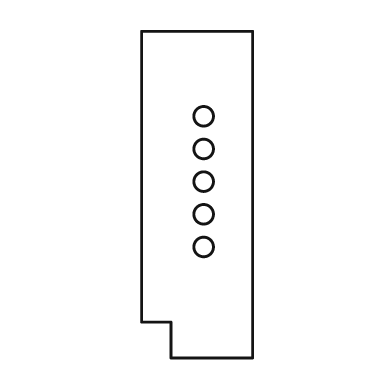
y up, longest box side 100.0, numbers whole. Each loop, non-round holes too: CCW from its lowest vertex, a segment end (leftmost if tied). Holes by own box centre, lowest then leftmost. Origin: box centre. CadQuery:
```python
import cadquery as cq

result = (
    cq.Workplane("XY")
    .moveTo(-8.0, -50.0)
    .lineTo(17.0, -50.0)
    .lineTo(17.0, 50.0)
    .lineTo(-17.0, 50.0)
    .lineTo(-17.0, -39.0)
    .lineTo(-8.0, -39.0)
    .close()
    .moveTo(2.0, -16.0)
    .circle(3.0)
    .moveTo(2.0, -6.0)
    .circle(3.0)
    .moveTo(2.0, 4.0)
    .circle(3.0)
    .moveTo(2.0, 14.0)
    .circle(3.0)
    .moveTo(2.0, 24.0)
    .circle(3.0)
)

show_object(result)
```